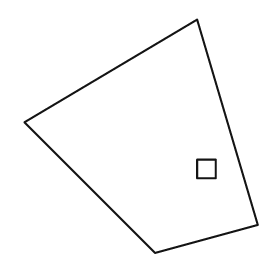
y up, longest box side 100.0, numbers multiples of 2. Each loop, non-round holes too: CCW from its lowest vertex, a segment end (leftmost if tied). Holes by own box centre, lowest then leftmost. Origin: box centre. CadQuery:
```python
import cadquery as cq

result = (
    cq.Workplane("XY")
    .moveTo(6.0, -50.0)
    .lineTo(50.0, -38.0)
    .lineTo(24.0, 50.0)
    .lineTo(-50.0, 6.0)
    .close()
    .moveTo(24.0, -18.0)
    .lineTo(32.0, -18.0)
    .lineTo(32.0, -10.0)
    .lineTo(24.0, -10.0)
    .close()
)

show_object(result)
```